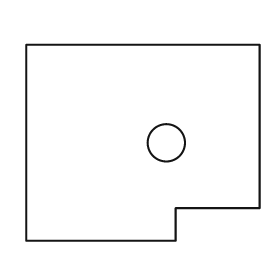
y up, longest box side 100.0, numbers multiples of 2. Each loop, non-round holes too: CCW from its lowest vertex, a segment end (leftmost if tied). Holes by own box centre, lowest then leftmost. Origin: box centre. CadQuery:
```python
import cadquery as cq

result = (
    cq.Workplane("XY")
    .moveTo(-50.0, -42.0)
    .lineTo(14.0, -42.0)
    .lineTo(14.0, -28.0)
    .lineTo(50.0, -28.0)
    .lineTo(50.0, 42.0)
    .lineTo(-50.0, 42.0)
    .close()
    .moveTo(10.0, 0.0)
    .circle(8.0)
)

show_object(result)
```